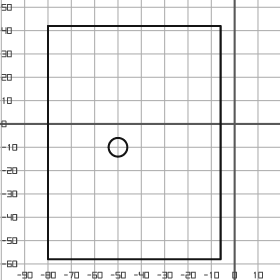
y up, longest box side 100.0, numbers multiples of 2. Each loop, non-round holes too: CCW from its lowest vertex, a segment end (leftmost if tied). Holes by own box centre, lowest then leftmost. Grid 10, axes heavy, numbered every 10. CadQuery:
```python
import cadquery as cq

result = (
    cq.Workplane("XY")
    .moveTo(-80.0, -58.0)
    .lineTo(-6.0, -58.0)
    .lineTo(-6.0, 42.0)
    .lineTo(-80.0, 42.0)
    .close()
    .moveTo(-50.0, -10.0)
    .circle(4.0)
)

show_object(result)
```